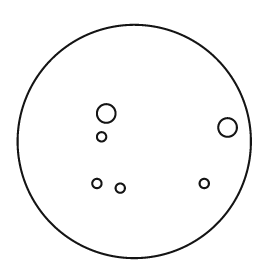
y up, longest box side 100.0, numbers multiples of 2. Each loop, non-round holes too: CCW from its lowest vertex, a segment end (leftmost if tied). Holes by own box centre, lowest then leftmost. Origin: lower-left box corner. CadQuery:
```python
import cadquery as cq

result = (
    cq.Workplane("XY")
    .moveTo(50.0, 50.0)
    .circle(50.0)
    .moveTo(44.0, 30.0)
    .circle(2.0)
    .moveTo(34.0, 32.0)
    .circle(2.0)
    .moveTo(80.0, 32.0)
    .circle(2.0)
    .moveTo(36.0, 52.0)
    .circle(2.0)
    .moveTo(90.0, 56.0)
    .circle(4.0)
    .moveTo(38.0, 62.0)
    .circle(4.0)
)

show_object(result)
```